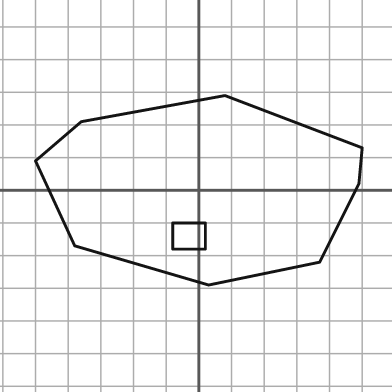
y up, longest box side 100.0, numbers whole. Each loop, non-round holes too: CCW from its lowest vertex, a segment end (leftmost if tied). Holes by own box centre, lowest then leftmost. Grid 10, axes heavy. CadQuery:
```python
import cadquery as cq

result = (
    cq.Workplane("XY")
    .moveTo(3.0, -29.0)
    .lineTo(37.0, -22.0)
    .lineTo(49.0, 2.0)
    .lineTo(50.0, 13.0)
    .lineTo(8.0, 29.0)
    .lineTo(-36.0, 21.0)
    .lineTo(-50.0, 9.0)
    .lineTo(-38.0, -17.0)
    .close()
    .moveTo(-8.0, -18.0)
    .lineTo(2.0, -18.0)
    .lineTo(2.0, -10.0)
    .lineTo(-8.0, -10.0)
    .close()
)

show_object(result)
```